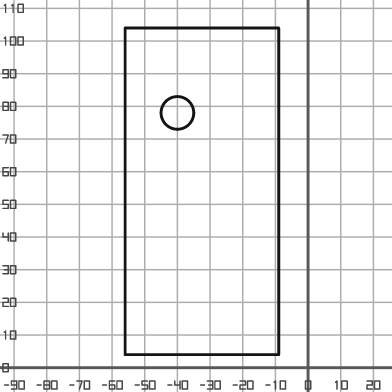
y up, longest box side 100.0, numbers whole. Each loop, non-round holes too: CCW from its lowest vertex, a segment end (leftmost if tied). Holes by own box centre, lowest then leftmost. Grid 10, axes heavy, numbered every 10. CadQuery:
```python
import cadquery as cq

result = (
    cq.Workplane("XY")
    .moveTo(-56.0, 4.0)
    .lineTo(-9.0, 4.0)
    .lineTo(-9.0, 104.0)
    .lineTo(-56.0, 104.0)
    .close()
    .moveTo(-40.0, 78.0)
    .circle(5.0)
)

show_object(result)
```